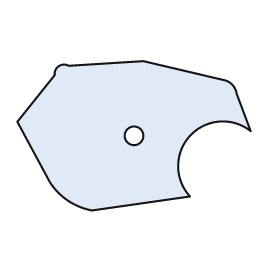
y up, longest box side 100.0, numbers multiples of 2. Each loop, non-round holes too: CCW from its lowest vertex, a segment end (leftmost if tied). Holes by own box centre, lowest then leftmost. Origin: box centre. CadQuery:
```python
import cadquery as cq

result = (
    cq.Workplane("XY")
    .moveTo(-18.0, -32.0)
    .lineTo(24.0, -26.0)
    .threePointArc((24.0, 0.0), (50.0, 2.0))
    .lineTo(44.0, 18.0)
    .threePointArc((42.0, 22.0), (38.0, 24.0))
    .lineTo(4.0, 32.0)
    .lineTo(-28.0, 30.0)
    .threePointArc((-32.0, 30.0), (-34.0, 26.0))
    .lineTo(-50.0, 6.0)
    .lineTo(-36.0, -20.0)
    .threePointArc((-28.0, -28.0), (-18.0, -32.0))
    .close()
    .moveTo(0.0, 0.0)
    .circle(4.0)
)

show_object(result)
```